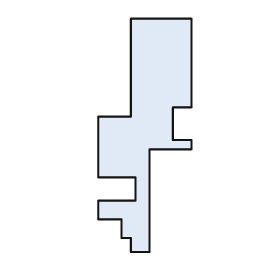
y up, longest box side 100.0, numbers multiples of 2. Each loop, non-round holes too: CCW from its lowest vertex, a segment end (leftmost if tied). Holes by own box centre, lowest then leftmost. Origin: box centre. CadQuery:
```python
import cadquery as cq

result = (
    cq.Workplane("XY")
    .moveTo(-6.0, -50.0)
    .lineTo(2.0, -50.0)
    .lineTo(2.0, -6.0)
    .lineTo(20.0, -6.0)
    .lineTo(20.0, -2.0)
    .lineTo(12.0, -2.0)
    .lineTo(12.0, 12.0)
    .lineTo(20.0, 12.0)
    .lineTo(20.0, 50.0)
    .lineTo(-6.0, 50.0)
    .lineTo(-6.0, 8.0)
    .lineTo(-20.0, 8.0)
    .lineTo(-20.0, -18.0)
    .lineTo(-4.0, -18.0)
    .lineTo(-4.0, -28.0)
    .lineTo(-20.0, -28.0)
    .lineTo(-20.0, -36.0)
    .lineTo(-10.0, -36.0)
    .lineTo(-10.0, -44.0)
    .lineTo(-6.0, -44.0)
    .close()
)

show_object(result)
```